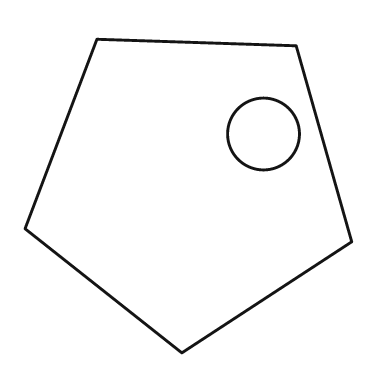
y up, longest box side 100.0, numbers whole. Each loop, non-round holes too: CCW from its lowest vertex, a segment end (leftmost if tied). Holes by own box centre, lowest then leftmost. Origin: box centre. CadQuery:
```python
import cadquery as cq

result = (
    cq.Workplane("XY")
    .moveTo(-2.0, -48.0)
    .lineTo(50.0, -14.0)
    .lineTo(33.0, 46.0)
    .lineTo(-28.0, 48.0)
    .lineTo(-50.0, -10.0)
    .close()
    .moveTo(23.0, 19.0)
    .circle(11.0)
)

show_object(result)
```